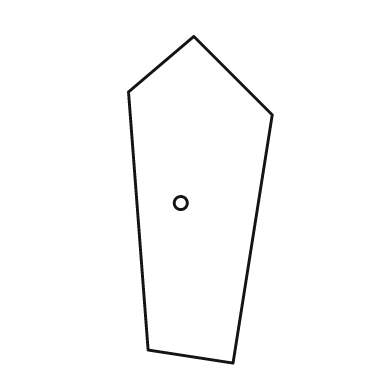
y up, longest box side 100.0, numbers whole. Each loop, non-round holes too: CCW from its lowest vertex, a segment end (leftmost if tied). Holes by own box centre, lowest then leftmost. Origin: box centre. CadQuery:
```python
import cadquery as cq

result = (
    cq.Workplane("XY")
    .moveTo(10.0, -50.0)
    .lineTo(22.0, 26.0)
    .lineTo(-2.0, 50.0)
    .lineTo(-22.0, 33.0)
    .lineTo(-16.0, -46.0)
    .close()
    .moveTo(-6.0, -1.0)
    .circle(2.0)
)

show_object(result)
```